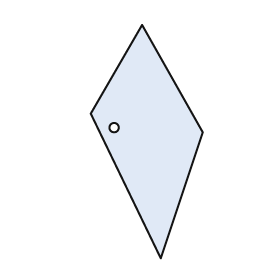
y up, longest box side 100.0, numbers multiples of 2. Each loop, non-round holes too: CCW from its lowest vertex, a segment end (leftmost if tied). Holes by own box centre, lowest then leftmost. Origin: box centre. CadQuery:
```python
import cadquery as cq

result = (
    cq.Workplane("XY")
    .moveTo(6.0, -50.0)
    .lineTo(24.0, 4.0)
    .lineTo(-2.0, 50.0)
    .lineTo(-24.0, 12.0)
    .close()
    .moveTo(-14.0, 6.0)
    .circle(2.0)
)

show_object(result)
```